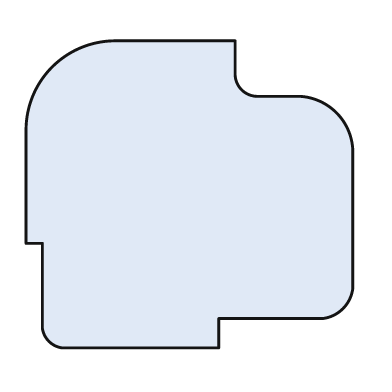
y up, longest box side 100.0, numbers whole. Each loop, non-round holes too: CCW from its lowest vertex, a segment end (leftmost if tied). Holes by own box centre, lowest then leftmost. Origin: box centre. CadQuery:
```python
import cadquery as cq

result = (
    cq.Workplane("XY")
    .moveTo(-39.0, -47.0)
    .lineTo(9.0, -47.0)
    .lineTo(9.0, -38.0)
    .lineTo(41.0, -38.0)
    .threePointArc((47.0, -35.0), (50.0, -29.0))
    .lineTo(50.0, 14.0)
    .threePointArc((45.0, 25.0), (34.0, 30.0))
    .lineTo(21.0, 30.0)
    .threePointArc((16.0, 32.0), (14.0, 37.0))
    .lineTo(14.0, 47.0)
    .lineTo(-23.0, 47.0)
    .threePointArc((-42.0, 39.0), (-50.0, 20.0))
    .lineTo(-50.0, -15.0)
    .lineTo(-45.0, -15.0)
    .lineTo(-45.0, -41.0)
    .threePointArc((-43.0, -45.0), (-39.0, -47.0))
    .close()
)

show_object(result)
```